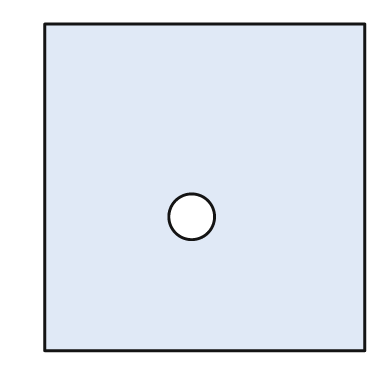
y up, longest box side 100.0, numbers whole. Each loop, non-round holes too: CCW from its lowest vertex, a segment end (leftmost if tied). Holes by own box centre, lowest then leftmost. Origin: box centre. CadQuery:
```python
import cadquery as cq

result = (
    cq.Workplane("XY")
    .moveTo(-49.0, -50.0)
    .lineTo(49.0, -50.0)
    .lineTo(49.0, 50.0)
    .lineTo(-49.0, 50.0)
    .close()
    .moveTo(-4.0, -9.0)
    .circle(7.0)
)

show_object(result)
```